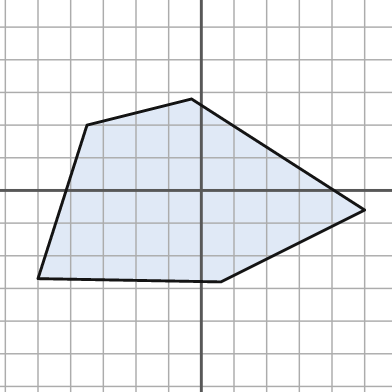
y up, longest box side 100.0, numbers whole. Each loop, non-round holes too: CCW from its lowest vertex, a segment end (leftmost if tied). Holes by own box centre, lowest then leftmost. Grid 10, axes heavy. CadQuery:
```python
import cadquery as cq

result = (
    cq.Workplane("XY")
    .moveTo(6.0, -28.0)
    .lineTo(50.0, -6.0)
    .lineTo(-3.0, 28.0)
    .lineTo(-35.0, 20.0)
    .lineTo(-50.0, -27.0)
    .close()
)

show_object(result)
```